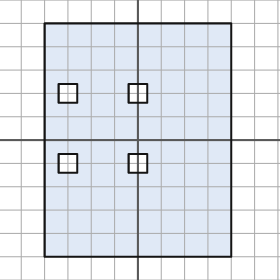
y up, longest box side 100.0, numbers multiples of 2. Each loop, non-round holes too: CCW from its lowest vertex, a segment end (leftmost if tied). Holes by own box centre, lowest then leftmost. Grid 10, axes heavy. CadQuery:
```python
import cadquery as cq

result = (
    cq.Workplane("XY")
    .moveTo(-40.0, -50.0)
    .lineTo(40.0, -50.0)
    .lineTo(40.0, 50.0)
    .lineTo(-40.0, 50.0)
    .close()
    .moveTo(-34.0, -14.0)
    .lineTo(-26.0, -14.0)
    .lineTo(-26.0, -6.0)
    .lineTo(-34.0, -6.0)
    .close()
    .moveTo(-4.0, -14.0)
    .lineTo(4.0, -14.0)
    .lineTo(4.0, -6.0)
    .lineTo(-4.0, -6.0)
    .close()
    .moveTo(-34.0, 16.0)
    .lineTo(-26.0, 16.0)
    .lineTo(-26.0, 24.0)
    .lineTo(-34.0, 24.0)
    .close()
    .moveTo(-4.0, 16.0)
    .lineTo(4.0, 16.0)
    .lineTo(4.0, 24.0)
    .lineTo(-4.0, 24.0)
    .close()
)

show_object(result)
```